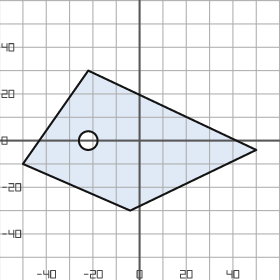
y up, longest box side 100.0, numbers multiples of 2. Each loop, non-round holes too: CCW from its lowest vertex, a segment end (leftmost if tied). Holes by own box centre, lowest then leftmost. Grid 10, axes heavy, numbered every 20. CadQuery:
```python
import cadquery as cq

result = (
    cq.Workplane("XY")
    .moveTo(-4.0, -30.0)
    .lineTo(50.0, -4.0)
    .lineTo(-22.0, 30.0)
    .lineTo(-50.0, -10.0)
    .close()
    .moveTo(-22.0, 0.0)
    .circle(4.0)
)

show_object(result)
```